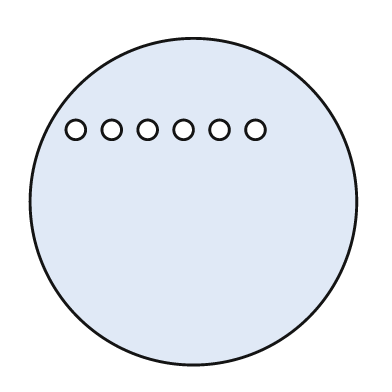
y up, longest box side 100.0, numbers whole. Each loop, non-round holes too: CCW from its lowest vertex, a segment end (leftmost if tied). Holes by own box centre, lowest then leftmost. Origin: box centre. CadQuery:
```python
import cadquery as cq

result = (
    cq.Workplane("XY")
    .moveTo(0.0, 0.0)
    .circle(50.0)
    .moveTo(-36.0, 22.0)
    .circle(3.0)
    .moveTo(-25.0, 22.0)
    .circle(3.0)
    .moveTo(-14.0, 22.0)
    .circle(3.0)
    .moveTo(-3.0, 22.0)
    .circle(3.0)
    .moveTo(8.0, 22.0)
    .circle(3.0)
    .moveTo(19.0, 22.0)
    .circle(3.0)
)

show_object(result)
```